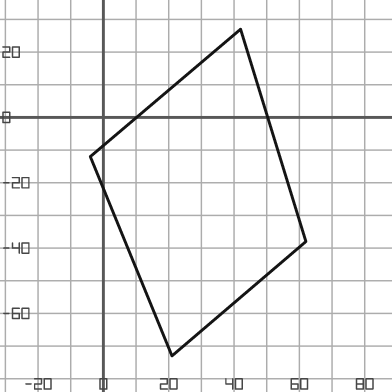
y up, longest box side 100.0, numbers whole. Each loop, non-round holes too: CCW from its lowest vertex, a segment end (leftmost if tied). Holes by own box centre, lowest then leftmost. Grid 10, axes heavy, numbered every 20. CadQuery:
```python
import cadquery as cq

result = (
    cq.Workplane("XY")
    .moveTo(21.0, -73.0)
    .lineTo(62.0, -38.0)
    .lineTo(42.0, 27.0)
    .lineTo(-4.0, -12.0)
    .close()
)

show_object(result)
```